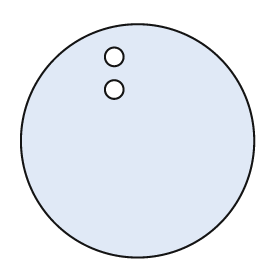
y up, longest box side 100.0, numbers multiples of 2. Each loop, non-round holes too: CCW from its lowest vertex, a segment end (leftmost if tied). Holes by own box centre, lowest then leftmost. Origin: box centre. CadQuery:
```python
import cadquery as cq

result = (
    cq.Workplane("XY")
    .moveTo(0.0, 0.0)
    .circle(50.0)
    .moveTo(-10.0, 22.0)
    .circle(4.0)
    .moveTo(-10.0, 36.0)
    .circle(4.0)
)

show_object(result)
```